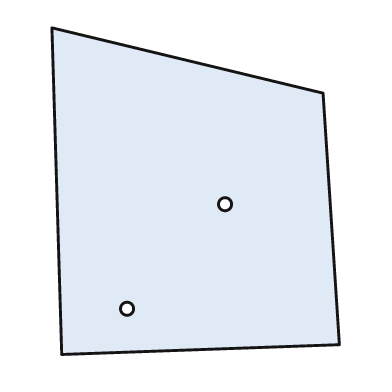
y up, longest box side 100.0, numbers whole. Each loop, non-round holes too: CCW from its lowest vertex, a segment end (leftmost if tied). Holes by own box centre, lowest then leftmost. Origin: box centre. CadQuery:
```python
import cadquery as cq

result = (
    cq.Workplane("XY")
    .moveTo(-41.0, -50.0)
    .lineTo(44.0, -47.0)
    .lineTo(39.0, 30.0)
    .lineTo(-44.0, 50.0)
    .close()
    .moveTo(-21.0, -36.0)
    .circle(2.0)
    .moveTo(9.0, -4.0)
    .circle(2.0)
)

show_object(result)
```